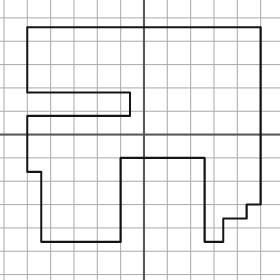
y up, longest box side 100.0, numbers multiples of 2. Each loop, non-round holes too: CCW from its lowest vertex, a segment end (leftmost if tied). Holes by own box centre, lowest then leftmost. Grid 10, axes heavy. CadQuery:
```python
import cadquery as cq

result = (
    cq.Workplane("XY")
    .moveTo(-44.0, -46.0)
    .lineTo(-10.0, -46.0)
    .lineTo(-10.0, -10.0)
    .lineTo(26.0, -10.0)
    .lineTo(26.0, -46.0)
    .lineTo(34.0, -46.0)
    .lineTo(34.0, -36.0)
    .lineTo(44.0, -36.0)
    .lineTo(44.0, -30.0)
    .lineTo(50.0, -30.0)
    .lineTo(50.0, 46.0)
    .lineTo(-50.0, 46.0)
    .lineTo(-50.0, 18.0)
    .lineTo(-6.0, 18.0)
    .lineTo(-6.0, 8.0)
    .lineTo(-50.0, 8.0)
    .lineTo(-50.0, -16.0)
    .lineTo(-44.0, -16.0)
    .close()
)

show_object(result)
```